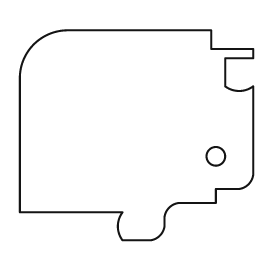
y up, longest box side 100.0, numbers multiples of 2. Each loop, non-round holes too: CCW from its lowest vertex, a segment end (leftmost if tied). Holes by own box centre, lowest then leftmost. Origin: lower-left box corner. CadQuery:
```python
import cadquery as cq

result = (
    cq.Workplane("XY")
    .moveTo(44.0, 0.0)
    .lineTo(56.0, 0.0)
    .threePointArc((60.0, 2.0), (62.0, 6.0))
    .lineTo(62.0, 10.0)
    .threePointArc((64.0, 14.0), (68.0, 16.0))
    .lineTo(84.0, 16.0)
    .lineTo(84.0, 22.0)
    .lineTo(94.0, 22.0)
    .threePointArc((98.0, 24.0), (100.0, 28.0))
    .lineTo(100.0, 66.0)
    .threePointArc((94.0, 64.0), (88.0, 66.0))
    .lineTo(88.0, 78.0)
    .lineTo(100.0, 78.0)
    .lineTo(100.0, 82.0)
    .lineTo(82.0, 82.0)
    .lineTo(82.0, 90.0)
    .lineTo(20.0, 90.0)
    .threePointArc((6.0, 84.0), (0.0, 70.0))
    .lineTo(0.0, 12.0)
    .lineTo(44.0, 12.0)
    .threePointArc((42.0, 6.0), (44.0, 0.0))
    .close()
    .moveTo(84.0, 36.0)
    .circle(4.0)
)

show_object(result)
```